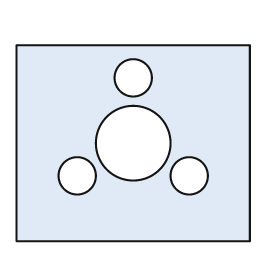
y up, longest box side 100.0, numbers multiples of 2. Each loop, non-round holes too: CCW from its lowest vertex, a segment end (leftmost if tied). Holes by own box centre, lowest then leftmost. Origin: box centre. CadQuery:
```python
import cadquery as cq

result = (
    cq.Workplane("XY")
    .moveTo(-50.0, -42.0)
    .lineTo(50.0, -42.0)
    .lineTo(50.0, 42.0)
    .lineTo(-50.0, 42.0)
    .close()
    .moveTo(-24.0, -14.0)
    .circle(8.0)
    .moveTo(24.0, -14.0)
    .circle(8.0)
    .moveTo(0.0, 0.0)
    .circle(16.0)
    .moveTo(0.0, 28.0)
    .circle(8.0)
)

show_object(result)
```